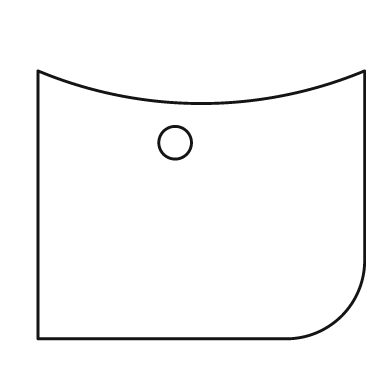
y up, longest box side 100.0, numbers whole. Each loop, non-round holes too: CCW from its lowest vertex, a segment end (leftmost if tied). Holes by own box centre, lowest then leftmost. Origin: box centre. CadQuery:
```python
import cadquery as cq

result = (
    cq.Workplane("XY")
    .moveTo(-50.0, -41.0)
    .lineTo(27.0, -41.0)
    .threePointArc((43.0, -34.0), (50.0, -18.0))
    .lineTo(50.0, 41.0)
    .threePointArc((0.0, 31.0), (-50.0, 41.0))
    .close()
    .moveTo(-8.0, 19.0)
    .circle(5.0)
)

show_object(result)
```